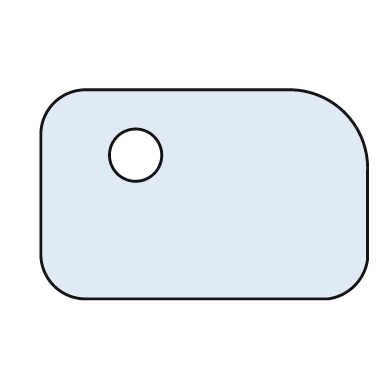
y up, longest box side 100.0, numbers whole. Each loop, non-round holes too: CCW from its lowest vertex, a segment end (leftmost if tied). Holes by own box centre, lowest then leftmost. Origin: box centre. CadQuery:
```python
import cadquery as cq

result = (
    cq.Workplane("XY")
    .moveTo(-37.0, -32.0)
    .lineTo(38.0, -32.0)
    .threePointArc((46.0, -28.0), (50.0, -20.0))
    .lineTo(50.0, 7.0)
    .threePointArc((43.0, 25.0), (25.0, 32.0))
    .lineTo(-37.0, 32.0)
    .threePointArc((-46.0, 28.0), (-50.0, 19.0))
    .lineTo(-50.0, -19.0)
    .threePointArc((-46.0, -28.0), (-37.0, -32.0))
    .close()
    .moveTo(-21.0, 12.0)
    .circle(8.0)
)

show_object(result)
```